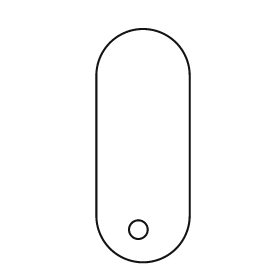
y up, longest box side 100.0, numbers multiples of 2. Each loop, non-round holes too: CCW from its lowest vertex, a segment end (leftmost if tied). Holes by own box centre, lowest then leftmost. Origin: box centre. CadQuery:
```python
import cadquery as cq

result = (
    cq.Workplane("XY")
    .moveTo(-20.0, -30.0)
    .threePointArc((0.0, -50.0), (20.0, -30.0))
    .lineTo(20.0, 30.0)
    .threePointArc((0.0, 50.0), (-20.0, 30.0))
    .close()
    .moveTo(-2.0, -36.0)
    .circle(4.0)
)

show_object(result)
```